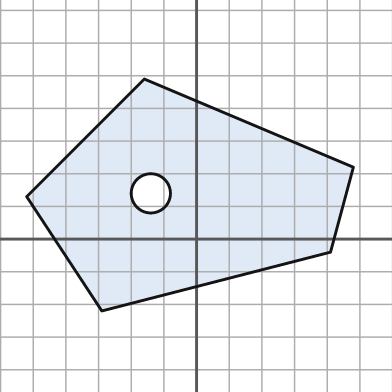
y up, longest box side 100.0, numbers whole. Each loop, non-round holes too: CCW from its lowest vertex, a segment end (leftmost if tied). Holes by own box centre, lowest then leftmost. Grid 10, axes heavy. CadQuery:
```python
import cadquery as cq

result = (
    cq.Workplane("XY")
    .moveTo(-29.0, -22.0)
    .lineTo(41.0, -4.0)
    .lineTo(48.0, 22.0)
    .lineTo(-16.0, 49.0)
    .lineTo(-52.0, 13.0)
    .close()
    .moveTo(-14.0, 14.0)
    .circle(6.0)
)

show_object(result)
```